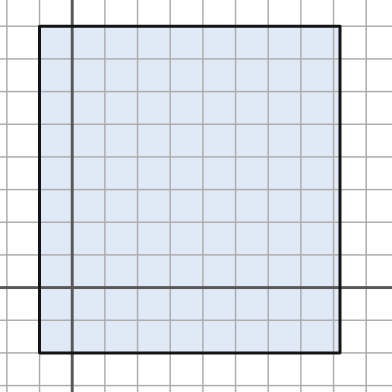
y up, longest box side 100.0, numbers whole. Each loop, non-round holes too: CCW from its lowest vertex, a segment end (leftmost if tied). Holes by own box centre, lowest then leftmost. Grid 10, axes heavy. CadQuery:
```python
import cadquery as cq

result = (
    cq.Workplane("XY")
    .moveTo(-10.0, -20.0)
    .lineTo(82.0, -20.0)
    .lineTo(82.0, 80.0)
    .lineTo(-10.0, 80.0)
    .close()
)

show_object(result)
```